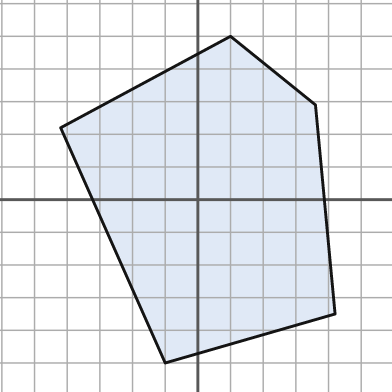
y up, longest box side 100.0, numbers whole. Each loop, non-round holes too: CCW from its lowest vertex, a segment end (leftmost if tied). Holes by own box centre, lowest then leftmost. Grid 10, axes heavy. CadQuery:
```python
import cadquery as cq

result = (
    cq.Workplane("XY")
    .moveTo(-10.0, -50.0)
    .lineTo(42.0, -35.0)
    .lineTo(36.0, 29.0)
    .lineTo(10.0, 50.0)
    .lineTo(-42.0, 22.0)
    .close()
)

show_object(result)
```